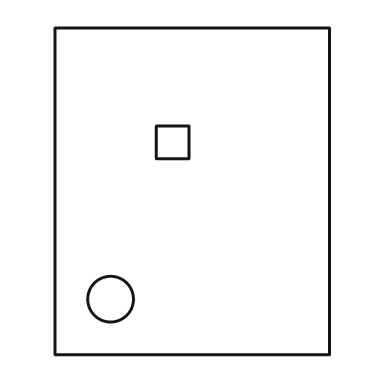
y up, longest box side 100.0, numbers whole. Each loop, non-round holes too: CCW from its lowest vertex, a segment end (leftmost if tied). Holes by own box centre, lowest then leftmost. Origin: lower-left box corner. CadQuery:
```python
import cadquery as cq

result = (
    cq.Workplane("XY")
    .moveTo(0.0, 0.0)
    .lineTo(84.0, 0.0)
    .lineTo(84.0, 100.0)
    .lineTo(0.0, 100.0)
    .close()
    .moveTo(17.0, 17.0)
    .circle(7.0)
    .moveTo(31.0, 60.0)
    .lineTo(41.0, 60.0)
    .lineTo(41.0, 70.0)
    .lineTo(31.0, 70.0)
    .close()
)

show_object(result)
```